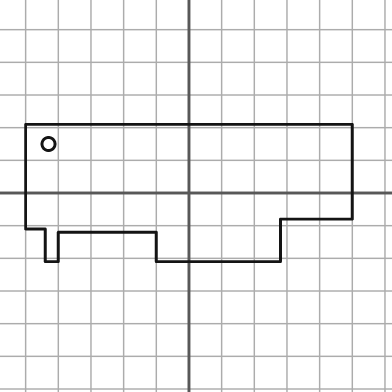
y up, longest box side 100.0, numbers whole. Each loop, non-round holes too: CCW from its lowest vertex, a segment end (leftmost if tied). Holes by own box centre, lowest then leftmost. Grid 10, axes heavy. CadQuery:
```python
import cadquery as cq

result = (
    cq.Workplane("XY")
    .moveTo(-44.0, -21.0)
    .lineTo(-40.0, -21.0)
    .lineTo(-40.0, -12.0)
    .lineTo(-10.0, -12.0)
    .lineTo(-10.0, -21.0)
    .lineTo(28.0, -21.0)
    .lineTo(28.0, -8.0)
    .lineTo(50.0, -8.0)
    .lineTo(50.0, 21.0)
    .lineTo(-50.0, 21.0)
    .lineTo(-50.0, -11.0)
    .lineTo(-44.0, -11.0)
    .close()
    .moveTo(-43.0, 15.0)
    .circle(2.0)
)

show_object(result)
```